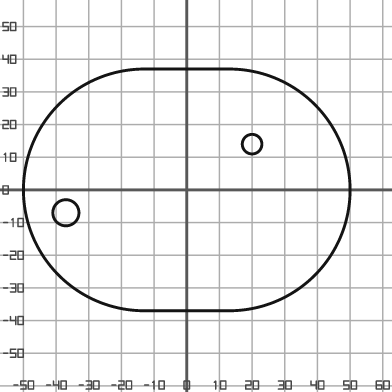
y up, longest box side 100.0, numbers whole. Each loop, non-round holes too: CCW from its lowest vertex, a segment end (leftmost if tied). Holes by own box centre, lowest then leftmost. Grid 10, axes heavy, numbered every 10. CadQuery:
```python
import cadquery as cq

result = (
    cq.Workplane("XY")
    .moveTo(-13.0, -37.0)
    .lineTo(13.0, -37.0)
    .threePointArc((50.0, 0.0), (13.0, 37.0))
    .lineTo(-13.0, 37.0)
    .threePointArc((-50.0, 0.0), (-13.0, -37.0))
    .close()
    .moveTo(-37.0, -7.0)
    .circle(4.0)
    .moveTo(20.0, 14.0)
    .circle(3.0)
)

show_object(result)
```